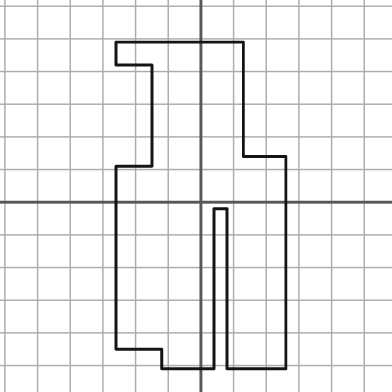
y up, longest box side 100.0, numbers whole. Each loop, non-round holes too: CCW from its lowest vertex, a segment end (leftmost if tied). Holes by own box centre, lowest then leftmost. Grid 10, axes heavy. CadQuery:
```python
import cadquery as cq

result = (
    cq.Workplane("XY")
    .moveTo(-12.0, -51.0)
    .lineTo(4.0, -51.0)
    .lineTo(4.0, -2.0)
    .lineTo(8.0, -2.0)
    .lineTo(8.0, -51.0)
    .lineTo(26.0, -51.0)
    .lineTo(26.0, 14.0)
    .lineTo(13.0, 14.0)
    .lineTo(13.0, 49.0)
    .lineTo(-26.0, 49.0)
    .lineTo(-26.0, 42.0)
    .lineTo(-15.0, 42.0)
    .lineTo(-15.0, 11.0)
    .lineTo(-26.0, 11.0)
    .lineTo(-26.0, -45.0)
    .lineTo(-12.0, -45.0)
    .close()
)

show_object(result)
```